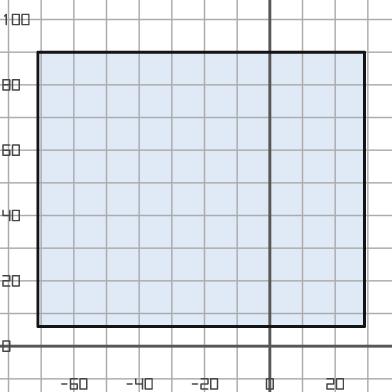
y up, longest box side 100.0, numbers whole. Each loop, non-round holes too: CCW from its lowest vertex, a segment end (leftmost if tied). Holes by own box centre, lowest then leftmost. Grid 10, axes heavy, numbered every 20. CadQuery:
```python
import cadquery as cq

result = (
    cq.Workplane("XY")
    .moveTo(-71.0, 6.0)
    .lineTo(29.0, 6.0)
    .lineTo(29.0, 90.0)
    .lineTo(-71.0, 90.0)
    .close()
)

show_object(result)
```